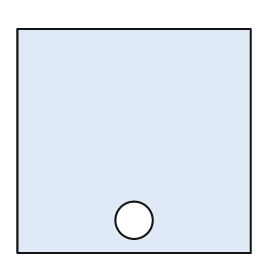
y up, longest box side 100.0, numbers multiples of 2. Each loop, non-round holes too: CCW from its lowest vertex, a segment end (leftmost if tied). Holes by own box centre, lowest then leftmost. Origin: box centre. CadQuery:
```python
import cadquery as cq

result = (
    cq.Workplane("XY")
    .moveTo(-50.0, -48.0)
    .lineTo(50.0, -48.0)
    .lineTo(50.0, 48.0)
    .lineTo(-50.0, 48.0)
    .close()
    .moveTo(0.0, -34.0)
    .circle(8.0)
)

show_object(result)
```